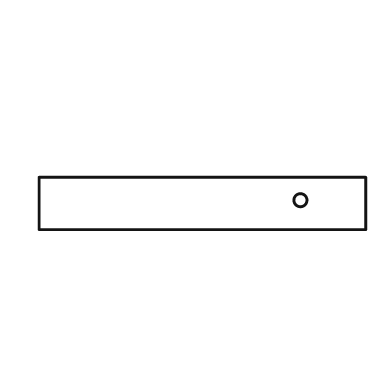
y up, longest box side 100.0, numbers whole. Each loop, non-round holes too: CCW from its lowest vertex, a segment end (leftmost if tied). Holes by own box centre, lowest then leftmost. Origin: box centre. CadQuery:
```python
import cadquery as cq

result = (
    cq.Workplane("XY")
    .moveTo(-50.0, -8.0)
    .lineTo(50.0, -8.0)
    .lineTo(50.0, 8.0)
    .lineTo(-50.0, 8.0)
    .close()
    .moveTo(30.0, 1.0)
    .circle(2.0)
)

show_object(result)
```